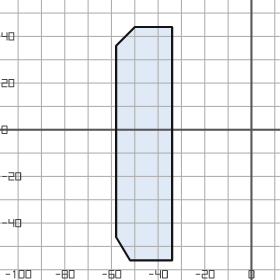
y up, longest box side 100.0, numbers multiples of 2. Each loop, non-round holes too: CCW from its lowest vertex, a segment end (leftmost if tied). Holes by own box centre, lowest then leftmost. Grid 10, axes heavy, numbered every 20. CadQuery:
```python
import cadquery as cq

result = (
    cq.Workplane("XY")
    .moveTo(-52.0, -56.0)
    .lineTo(-34.0, -56.0)
    .lineTo(-34.0, 44.0)
    .lineTo(-50.0, 44.0)
    .lineTo(-58.0, 36.0)
    .lineTo(-58.0, -46.0)
    .close()
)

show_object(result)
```